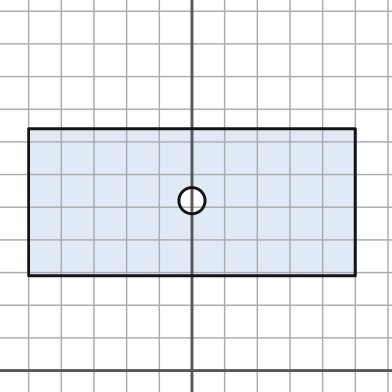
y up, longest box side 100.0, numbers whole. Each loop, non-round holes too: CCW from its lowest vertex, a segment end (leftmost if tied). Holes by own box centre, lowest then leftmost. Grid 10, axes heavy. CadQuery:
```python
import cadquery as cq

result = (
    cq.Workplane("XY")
    .moveTo(-50.0, 29.0)
    .lineTo(50.0, 29.0)
    .lineTo(50.0, 74.0)
    .lineTo(-50.0, 74.0)
    .close()
    .moveTo(0.0, 52.0)
    .circle(4.0)
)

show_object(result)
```